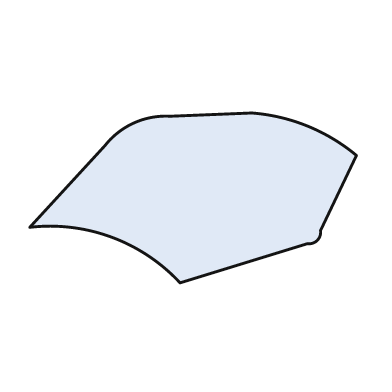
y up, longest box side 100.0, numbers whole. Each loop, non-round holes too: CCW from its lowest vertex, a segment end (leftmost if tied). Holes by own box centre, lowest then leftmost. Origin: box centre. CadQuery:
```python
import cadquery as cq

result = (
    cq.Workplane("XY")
    .moveTo(-4.0, -26.0)
    .lineTo(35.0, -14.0)
    .threePointArc((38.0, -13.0), (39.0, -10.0))
    .lineTo(50.0, 13.0)
    .threePointArc((35.0, 22.0), (18.0, 26.0))
    .lineTo(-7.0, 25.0)
    .threePointArc((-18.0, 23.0), (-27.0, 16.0))
    .lineTo(-50.0, -9.0)
    .threePointArc((-25.0, -12.0), (-4.0, -26.0))
    .close()
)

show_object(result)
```